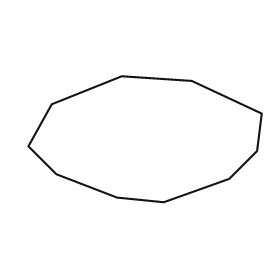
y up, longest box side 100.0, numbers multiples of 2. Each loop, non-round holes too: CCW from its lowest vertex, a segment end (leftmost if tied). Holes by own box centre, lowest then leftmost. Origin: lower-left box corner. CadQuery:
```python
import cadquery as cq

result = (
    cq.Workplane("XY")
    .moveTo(58.0, 0.0)
    .lineTo(86.0, 10.0)
    .lineTo(98.0, 22.0)
    .lineTo(100.0, 38.0)
    .lineTo(70.0, 52.0)
    .lineTo(40.0, 54.0)
    .lineTo(10.0, 42.0)
    .lineTo(0.0, 24.0)
    .lineTo(12.0, 12.0)
    .lineTo(38.0, 2.0)
    .close()
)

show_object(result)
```